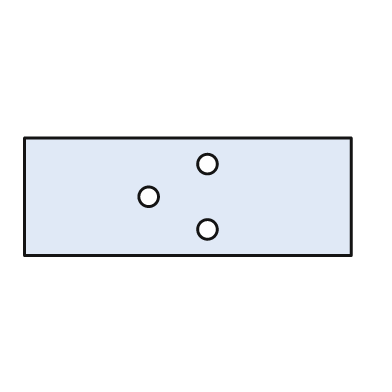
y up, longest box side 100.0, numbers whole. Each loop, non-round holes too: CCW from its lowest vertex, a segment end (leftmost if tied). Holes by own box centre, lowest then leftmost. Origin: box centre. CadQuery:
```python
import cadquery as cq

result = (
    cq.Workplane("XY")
    .moveTo(-50.0, -18.0)
    .lineTo(50.0, -18.0)
    .lineTo(50.0, 18.0)
    .lineTo(-50.0, 18.0)
    .close()
    .moveTo(6.0, -10.0)
    .circle(3.0)
    .moveTo(-12.0, 0.0)
    .circle(3.0)
    .moveTo(6.0, 10.0)
    .circle(3.0)
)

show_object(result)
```